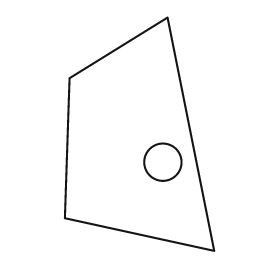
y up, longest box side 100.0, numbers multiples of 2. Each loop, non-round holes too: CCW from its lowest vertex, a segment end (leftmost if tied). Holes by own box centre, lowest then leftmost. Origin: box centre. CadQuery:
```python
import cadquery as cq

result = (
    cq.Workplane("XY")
    .moveTo(32.0, -50.0)
    .lineTo(12.0, 50.0)
    .lineTo(-30.0, 24.0)
    .lineTo(-32.0, -36.0)
    .close()
    .moveTo(10.0, -12.0)
    .circle(8.0)
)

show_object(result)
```